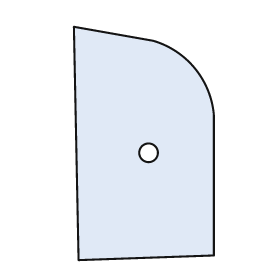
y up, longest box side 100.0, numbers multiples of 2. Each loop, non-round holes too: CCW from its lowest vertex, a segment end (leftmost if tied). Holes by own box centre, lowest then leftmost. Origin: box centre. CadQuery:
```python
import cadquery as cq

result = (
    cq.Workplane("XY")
    .moveTo(-28.0, -50.0)
    .lineTo(30.0, -48.0)
    .lineTo(30.0, 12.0)
    .threePointArc((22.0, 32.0), (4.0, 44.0))
    .lineTo(-30.0, 50.0)
    .close()
    .moveTo(2.0, -4.0)
    .circle(4.0)
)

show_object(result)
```